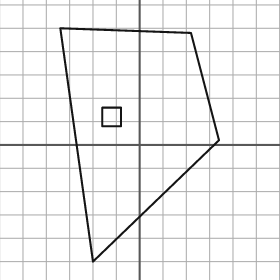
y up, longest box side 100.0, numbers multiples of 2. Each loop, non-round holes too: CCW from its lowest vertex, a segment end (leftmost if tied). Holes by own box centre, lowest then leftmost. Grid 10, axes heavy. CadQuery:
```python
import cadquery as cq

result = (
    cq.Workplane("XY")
    .moveTo(-20.0, -50.0)
    .lineTo(34.0, 2.0)
    .lineTo(22.0, 48.0)
    .lineTo(-34.0, 50.0)
    .close()
    .moveTo(-16.0, 8.0)
    .lineTo(-8.0, 8.0)
    .lineTo(-8.0, 16.0)
    .lineTo(-16.0, 16.0)
    .close()
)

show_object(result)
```